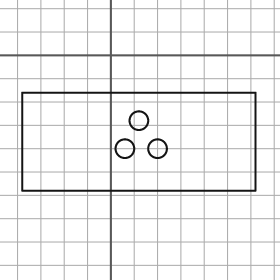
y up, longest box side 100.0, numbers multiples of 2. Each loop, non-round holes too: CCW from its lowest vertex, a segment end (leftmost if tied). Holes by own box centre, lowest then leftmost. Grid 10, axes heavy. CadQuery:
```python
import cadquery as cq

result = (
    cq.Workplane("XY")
    .moveTo(-38.0, -58.0)
    .lineTo(62.0, -58.0)
    .lineTo(62.0, -16.0)
    .lineTo(-38.0, -16.0)
    .close()
    .moveTo(6.0, -40.0)
    .circle(4.0)
    .moveTo(20.0, -40.0)
    .circle(4.0)
    .moveTo(12.0, -28.0)
    .circle(4.0)
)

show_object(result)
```